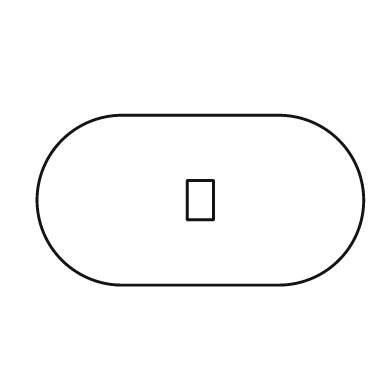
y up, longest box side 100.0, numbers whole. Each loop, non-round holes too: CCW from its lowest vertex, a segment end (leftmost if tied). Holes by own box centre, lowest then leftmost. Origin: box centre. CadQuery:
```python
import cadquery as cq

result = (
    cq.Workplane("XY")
    .moveTo(-24.0, -26.0)
    .lineTo(24.0, -26.0)
    .threePointArc((50.0, 0.0), (24.0, 26.0))
    .lineTo(-24.0, 26.0)
    .threePointArc((-50.0, 0.0), (-24.0, -26.0))
    .close()
    .moveTo(-4.0, -6.0)
    .lineTo(4.0, -6.0)
    .lineTo(4.0, 6.0)
    .lineTo(-4.0, 6.0)
    .close()
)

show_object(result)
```